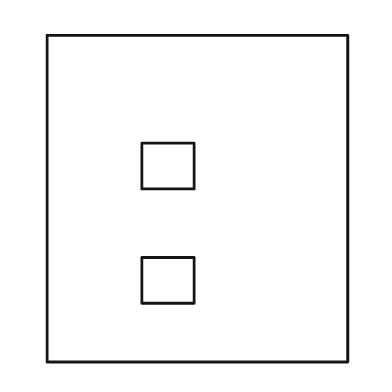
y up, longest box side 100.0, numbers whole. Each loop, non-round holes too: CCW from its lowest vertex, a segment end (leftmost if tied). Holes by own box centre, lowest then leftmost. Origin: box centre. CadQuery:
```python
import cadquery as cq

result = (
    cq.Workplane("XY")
    .moveTo(-46.0, -50.0)
    .lineTo(46.0, -50.0)
    .lineTo(46.0, 50.0)
    .lineTo(-46.0, 50.0)
    .close()
    .moveTo(-17.0, -32.0)
    .lineTo(-1.0, -32.0)
    .lineTo(-1.0, -18.0)
    .lineTo(-17.0, -18.0)
    .close()
    .moveTo(-17.0, 3.0)
    .lineTo(-1.0, 3.0)
    .lineTo(-1.0, 17.0)
    .lineTo(-17.0, 17.0)
    .close()
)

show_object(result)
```